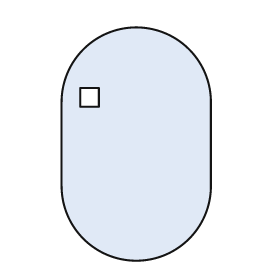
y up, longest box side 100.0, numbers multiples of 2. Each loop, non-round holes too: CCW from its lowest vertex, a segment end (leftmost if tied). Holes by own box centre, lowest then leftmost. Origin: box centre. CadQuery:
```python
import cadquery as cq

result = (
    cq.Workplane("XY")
    .moveTo(-32.0, -18.0)
    .threePointArc((0.0, -50.0), (32.0, -18.0))
    .lineTo(32.0, 18.0)
    .threePointArc((0.0, 50.0), (-32.0, 18.0))
    .close()
    .moveTo(-24.0, 16.0)
    .lineTo(-16.0, 16.0)
    .lineTo(-16.0, 24.0)
    .lineTo(-24.0, 24.0)
    .close()
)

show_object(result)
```